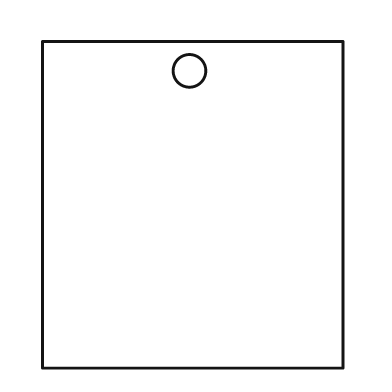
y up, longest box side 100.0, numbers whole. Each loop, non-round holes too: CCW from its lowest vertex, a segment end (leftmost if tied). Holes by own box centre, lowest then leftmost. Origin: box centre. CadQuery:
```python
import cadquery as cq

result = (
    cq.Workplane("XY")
    .moveTo(-46.0, -50.0)
    .lineTo(46.0, -50.0)
    .lineTo(46.0, 50.0)
    .lineTo(-46.0, 50.0)
    .close()
    .moveTo(-1.0, 41.0)
    .circle(5.0)
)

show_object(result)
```